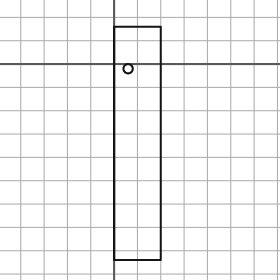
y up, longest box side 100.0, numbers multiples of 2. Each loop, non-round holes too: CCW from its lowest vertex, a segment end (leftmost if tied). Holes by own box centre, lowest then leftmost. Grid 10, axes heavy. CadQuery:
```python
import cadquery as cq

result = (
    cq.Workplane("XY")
    .moveTo(0.0, -84.0)
    .lineTo(20.0, -84.0)
    .lineTo(20.0, 16.0)
    .lineTo(0.0, 16.0)
    .close()
    .moveTo(6.0, -2.0)
    .circle(2.0)
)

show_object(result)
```